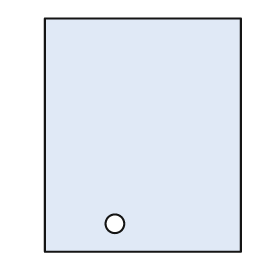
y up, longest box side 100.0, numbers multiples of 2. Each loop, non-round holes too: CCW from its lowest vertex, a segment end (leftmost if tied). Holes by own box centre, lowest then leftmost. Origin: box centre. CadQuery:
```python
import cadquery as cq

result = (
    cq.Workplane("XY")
    .moveTo(-42.0, -50.0)
    .lineTo(42.0, -50.0)
    .lineTo(42.0, 50.0)
    .lineTo(-42.0, 50.0)
    .close()
    .moveTo(-12.0, -38.0)
    .circle(4.0)
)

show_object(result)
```